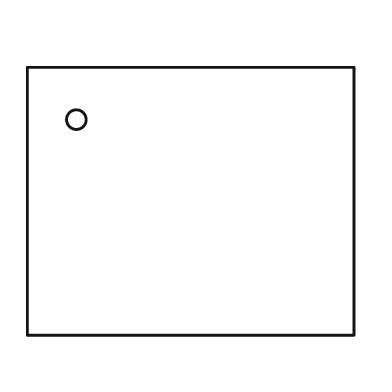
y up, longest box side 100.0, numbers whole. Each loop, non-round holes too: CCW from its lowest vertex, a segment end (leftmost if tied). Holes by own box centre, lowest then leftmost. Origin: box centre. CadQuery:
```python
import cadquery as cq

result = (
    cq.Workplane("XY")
    .moveTo(-50.0, -41.0)
    .lineTo(50.0, -41.0)
    .lineTo(50.0, 41.0)
    .lineTo(-50.0, 41.0)
    .close()
    .moveTo(-35.0, 25.0)
    .circle(3.0)
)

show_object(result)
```